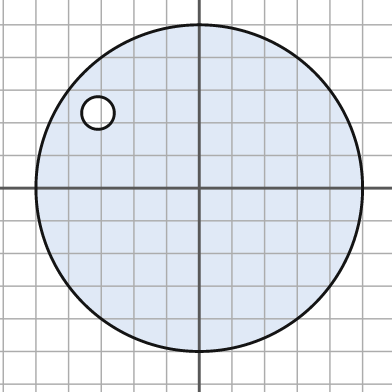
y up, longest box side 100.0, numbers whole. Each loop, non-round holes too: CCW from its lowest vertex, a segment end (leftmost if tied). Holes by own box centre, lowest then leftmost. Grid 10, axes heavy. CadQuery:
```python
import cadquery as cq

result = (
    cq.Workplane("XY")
    .moveTo(0.0, 0.0)
    .circle(50.0)
    .moveTo(-31.0, 23.0)
    .circle(5.0)
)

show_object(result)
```